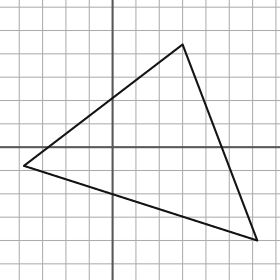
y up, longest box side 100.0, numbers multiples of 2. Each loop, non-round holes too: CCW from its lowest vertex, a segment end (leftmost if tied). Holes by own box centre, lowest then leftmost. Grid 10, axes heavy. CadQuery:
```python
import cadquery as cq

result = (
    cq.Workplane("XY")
    .moveTo(62.0, -40.0)
    .lineTo(30.0, 44.0)
    .lineTo(-38.0, -8.0)
    .close()
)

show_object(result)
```